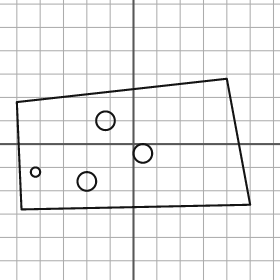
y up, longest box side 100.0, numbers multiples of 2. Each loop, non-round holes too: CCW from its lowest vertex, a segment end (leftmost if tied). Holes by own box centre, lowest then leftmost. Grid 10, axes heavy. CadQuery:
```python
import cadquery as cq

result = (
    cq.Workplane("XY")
    .moveTo(-48.0, -28.0)
    .lineTo(50.0, -26.0)
    .lineTo(40.0, 28.0)
    .lineTo(-50.0, 18.0)
    .close()
    .moveTo(-20.0, -16.0)
    .circle(4.0)
    .moveTo(-42.0, -12.0)
    .circle(2.0)
    .moveTo(4.0, -4.0)
    .circle(4.0)
    .moveTo(-12.0, 10.0)
    .circle(4.0)
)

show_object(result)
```